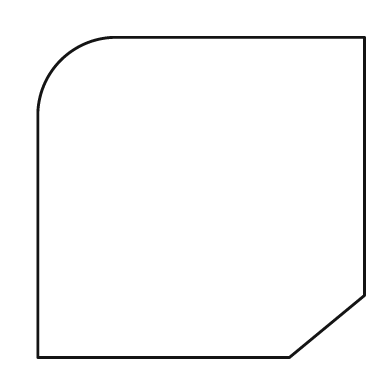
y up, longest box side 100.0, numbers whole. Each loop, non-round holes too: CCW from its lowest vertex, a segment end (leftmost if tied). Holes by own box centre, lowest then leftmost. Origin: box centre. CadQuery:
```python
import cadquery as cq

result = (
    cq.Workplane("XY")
    .moveTo(-50.0, -49.0)
    .lineTo(27.0, -49.0)
    .lineTo(50.0, -30.0)
    .lineTo(50.0, 49.0)
    .lineTo(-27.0, 49.0)
    .threePointArc((-43.0, 42.0), (-50.0, 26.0))
    .close()
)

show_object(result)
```